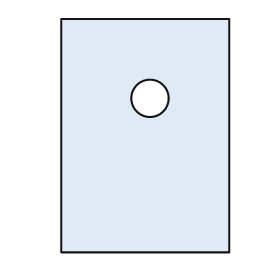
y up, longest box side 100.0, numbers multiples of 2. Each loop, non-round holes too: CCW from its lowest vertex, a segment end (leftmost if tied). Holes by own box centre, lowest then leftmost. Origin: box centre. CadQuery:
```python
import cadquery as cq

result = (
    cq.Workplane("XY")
    .moveTo(-36.0, -50.0)
    .lineTo(36.0, -50.0)
    .lineTo(36.0, 50.0)
    .lineTo(-36.0, 50.0)
    .close()
    .moveTo(2.0, 16.0)
    .circle(8.0)
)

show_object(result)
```